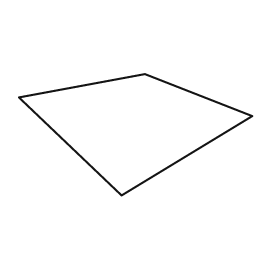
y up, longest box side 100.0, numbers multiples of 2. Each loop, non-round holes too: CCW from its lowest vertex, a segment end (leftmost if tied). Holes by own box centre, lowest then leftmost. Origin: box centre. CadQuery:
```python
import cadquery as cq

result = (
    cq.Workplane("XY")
    .moveTo(-6.0, -26.0)
    .lineTo(50.0, 8.0)
    .lineTo(4.0, 26.0)
    .lineTo(-50.0, 16.0)
    .close()
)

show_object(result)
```